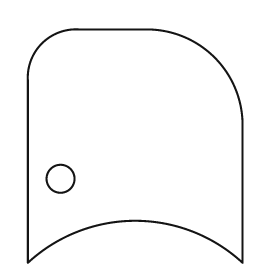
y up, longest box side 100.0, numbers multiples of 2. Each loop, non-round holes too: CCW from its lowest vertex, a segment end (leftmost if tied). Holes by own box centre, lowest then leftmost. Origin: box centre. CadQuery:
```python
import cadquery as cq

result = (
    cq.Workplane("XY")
    .moveTo(-46.0, -50.0)
    .threePointArc((0.0, -32.0), (46.0, -50.0))
    .lineTo(46.0, 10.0)
    .threePointArc((34.0, 38.0), (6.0, 50.0))
    .lineTo(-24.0, 50.0)
    .threePointArc((-40.0, 44.0), (-46.0, 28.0))
    .close()
    .moveTo(-32.0, -14.0)
    .circle(6.0)
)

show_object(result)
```